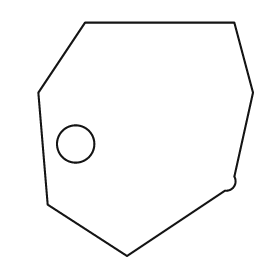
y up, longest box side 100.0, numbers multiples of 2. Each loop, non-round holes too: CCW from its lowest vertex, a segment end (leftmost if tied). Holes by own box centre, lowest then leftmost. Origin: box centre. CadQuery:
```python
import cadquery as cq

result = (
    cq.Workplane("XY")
    .moveTo(-8.0, -50.0)
    .lineTo(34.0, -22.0)
    .threePointArc((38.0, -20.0), (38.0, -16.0))
    .lineTo(46.0, 20.0)
    .lineTo(38.0, 50.0)
    .lineTo(-26.0, 50.0)
    .lineTo(-46.0, 20.0)
    .lineTo(-42.0, -28.0)
    .close()
    .moveTo(-30.0, -2.0)
    .circle(8.0)
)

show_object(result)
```